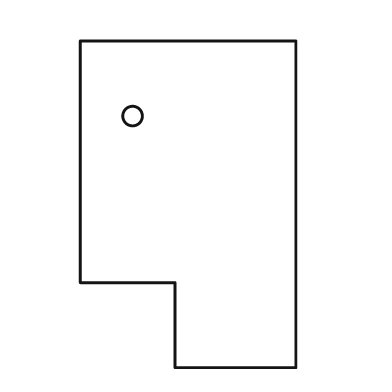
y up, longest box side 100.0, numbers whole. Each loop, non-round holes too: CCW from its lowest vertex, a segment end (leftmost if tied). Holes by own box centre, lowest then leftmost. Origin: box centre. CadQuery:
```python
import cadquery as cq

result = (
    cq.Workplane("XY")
    .moveTo(-4.0, -50.0)
    .lineTo(33.0, -50.0)
    .lineTo(33.0, 50.0)
    .lineTo(-33.0, 50.0)
    .lineTo(-33.0, -24.0)
    .lineTo(-4.0, -24.0)
    .close()
    .moveTo(-17.0, 27.0)
    .circle(3.0)
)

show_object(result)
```